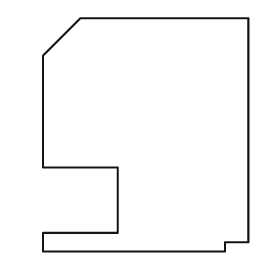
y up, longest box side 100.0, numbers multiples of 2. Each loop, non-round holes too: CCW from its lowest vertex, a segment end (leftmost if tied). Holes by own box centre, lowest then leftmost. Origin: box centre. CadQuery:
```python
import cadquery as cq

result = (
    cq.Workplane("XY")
    .moveTo(-44.0, -50.0)
    .lineTo(34.0, -50.0)
    .lineTo(34.0, -46.0)
    .lineTo(44.0, -46.0)
    .lineTo(44.0, 50.0)
    .lineTo(-28.0, 50.0)
    .lineTo(-44.0, 34.0)
    .lineTo(-44.0, -14.0)
    .lineTo(-12.0, -14.0)
    .lineTo(-12.0, -42.0)
    .lineTo(-44.0, -42.0)
    .close()
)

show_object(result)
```